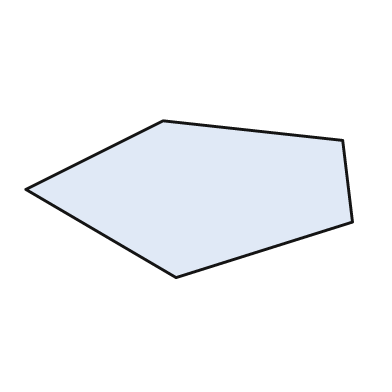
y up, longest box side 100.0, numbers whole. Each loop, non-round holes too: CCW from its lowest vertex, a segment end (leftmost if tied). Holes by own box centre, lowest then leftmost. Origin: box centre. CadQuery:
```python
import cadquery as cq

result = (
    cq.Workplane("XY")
    .moveTo(-4.0, -24.0)
    .lineTo(50.0, -7.0)
    .lineTo(47.0, 18.0)
    .lineTo(-8.0, 24.0)
    .lineTo(-50.0, 3.0)
    .close()
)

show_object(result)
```